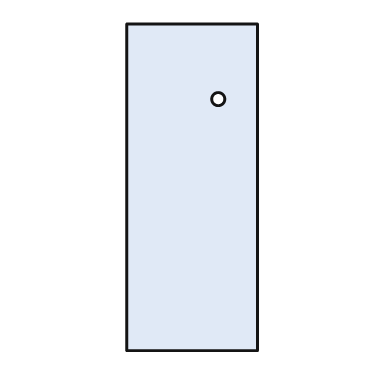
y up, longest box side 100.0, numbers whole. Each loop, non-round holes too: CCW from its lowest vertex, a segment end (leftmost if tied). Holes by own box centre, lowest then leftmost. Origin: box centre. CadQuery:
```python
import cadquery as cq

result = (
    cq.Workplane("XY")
    .moveTo(-20.0, -50.0)
    .lineTo(20.0, -50.0)
    .lineTo(20.0, 50.0)
    .lineTo(-20.0, 50.0)
    .close()
    .moveTo(8.0, 27.0)
    .circle(2.0)
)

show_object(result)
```